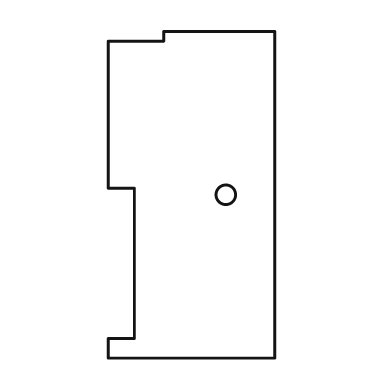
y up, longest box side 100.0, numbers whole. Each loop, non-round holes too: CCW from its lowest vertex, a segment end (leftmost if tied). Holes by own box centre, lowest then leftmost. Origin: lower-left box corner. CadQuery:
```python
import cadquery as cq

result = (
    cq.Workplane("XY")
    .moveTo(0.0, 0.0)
    .lineTo(51.0, 0.0)
    .lineTo(51.0, 100.0)
    .lineTo(17.0, 100.0)
    .lineTo(17.0, 97.0)
    .lineTo(0.0, 97.0)
    .lineTo(0.0, 52.0)
    .lineTo(8.0, 52.0)
    .lineTo(8.0, 6.0)
    .lineTo(0.0, 6.0)
    .close()
    .moveTo(36.0, 50.0)
    .circle(3.0)
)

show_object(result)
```